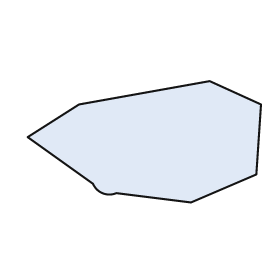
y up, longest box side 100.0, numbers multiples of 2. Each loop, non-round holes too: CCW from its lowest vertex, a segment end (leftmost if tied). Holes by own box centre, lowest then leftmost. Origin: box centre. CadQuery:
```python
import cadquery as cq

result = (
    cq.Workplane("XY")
    .moveTo(20.0, -26.0)
    .lineTo(48.0, -14.0)
    .lineTo(50.0, 16.0)
    .lineTo(28.0, 26.0)
    .lineTo(-28.0, 16.0)
    .lineTo(-50.0, 2.0)
    .lineTo(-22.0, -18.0)
    .threePointArc((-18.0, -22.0), (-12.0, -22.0))
    .close()
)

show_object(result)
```